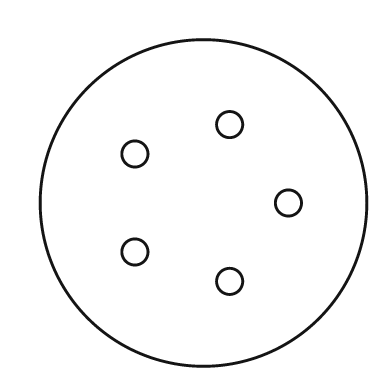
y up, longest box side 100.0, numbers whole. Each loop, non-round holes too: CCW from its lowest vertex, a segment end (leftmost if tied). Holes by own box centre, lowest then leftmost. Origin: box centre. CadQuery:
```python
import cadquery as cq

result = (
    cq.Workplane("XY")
    .moveTo(0.0, 0.0)
    .circle(50.0)
    .moveTo(8.0, -24.0)
    .circle(4.0)
    .moveTo(-21.0, -15.0)
    .circle(4.0)
    .moveTo(26.0, 0.0)
    .circle(4.0)
    .moveTo(-21.0, 15.0)
    .circle(4.0)
    .moveTo(8.0, 24.0)
    .circle(4.0)
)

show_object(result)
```